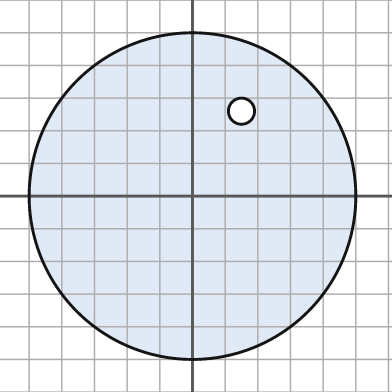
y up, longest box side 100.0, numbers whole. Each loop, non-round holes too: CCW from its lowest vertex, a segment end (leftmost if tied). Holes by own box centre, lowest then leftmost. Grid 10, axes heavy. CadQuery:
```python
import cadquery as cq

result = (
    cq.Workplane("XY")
    .moveTo(0.0, 0.0)
    .circle(50.0)
    .moveTo(15.0, 26.0)
    .circle(4.0)
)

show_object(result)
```